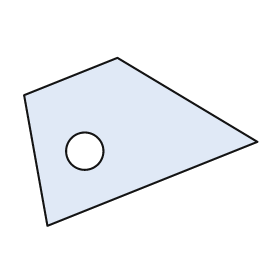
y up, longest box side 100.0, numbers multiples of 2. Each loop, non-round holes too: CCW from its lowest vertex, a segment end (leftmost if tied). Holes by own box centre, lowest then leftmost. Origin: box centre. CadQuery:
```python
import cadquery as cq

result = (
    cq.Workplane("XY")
    .moveTo(-40.0, -36.0)
    .lineTo(50.0, 0.0)
    .lineTo(-10.0, 36.0)
    .lineTo(-50.0, 20.0)
    .close()
    .moveTo(-24.0, -4.0)
    .circle(8.0)
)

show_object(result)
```